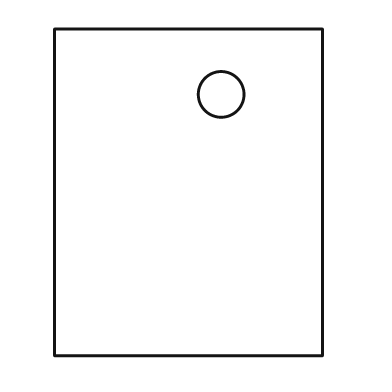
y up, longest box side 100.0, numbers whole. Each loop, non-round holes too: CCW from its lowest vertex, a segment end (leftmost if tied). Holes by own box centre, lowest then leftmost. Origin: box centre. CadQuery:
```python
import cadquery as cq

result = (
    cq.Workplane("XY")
    .moveTo(-41.0, -50.0)
    .lineTo(41.0, -50.0)
    .lineTo(41.0, 50.0)
    .lineTo(-41.0, 50.0)
    .close()
    .moveTo(10.0, 30.0)
    .circle(7.0)
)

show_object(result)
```